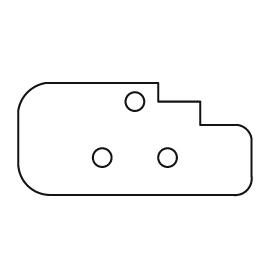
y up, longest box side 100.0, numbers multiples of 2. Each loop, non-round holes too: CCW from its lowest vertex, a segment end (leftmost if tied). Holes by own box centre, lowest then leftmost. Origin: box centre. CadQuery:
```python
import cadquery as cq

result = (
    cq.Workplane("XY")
    .moveTo(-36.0, -24.0)
    .lineTo(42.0, -24.0)
    .threePointArc((48.0, -22.0), (50.0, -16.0))
    .lineTo(50.0, 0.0)
    .threePointArc((48.0, 4.0), (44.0, 6.0))
    .lineTo(28.0, 6.0)
    .lineTo(28.0, 16.0)
    .lineTo(10.0, 16.0)
    .lineTo(10.0, 24.0)
    .lineTo(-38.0, 24.0)
    .threePointArc((-46.0, 20.0), (-50.0, 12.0))
    .lineTo(-50.0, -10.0)
    .threePointArc((-46.0, -20.0), (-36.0, -24.0))
    .close()
    .moveTo(-14.0, -8.0)
    .circle(4.0)
    .moveTo(14.0, -8.0)
    .circle(4.0)
    .moveTo(0.0, 16.0)
    .circle(4.0)
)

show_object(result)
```